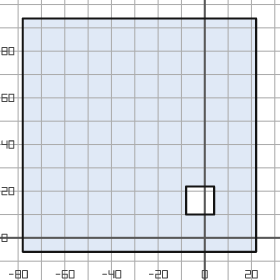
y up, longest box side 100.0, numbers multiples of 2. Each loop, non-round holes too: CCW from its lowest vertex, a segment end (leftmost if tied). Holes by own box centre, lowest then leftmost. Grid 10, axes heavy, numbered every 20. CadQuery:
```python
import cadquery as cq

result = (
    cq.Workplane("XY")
    .moveTo(-78.0, -6.0)
    .lineTo(22.0, -6.0)
    .lineTo(22.0, 94.0)
    .lineTo(-78.0, 94.0)
    .close()
    .moveTo(-8.0, 10.0)
    .lineTo(4.0, 10.0)
    .lineTo(4.0, 22.0)
    .lineTo(-8.0, 22.0)
    .close()
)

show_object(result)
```